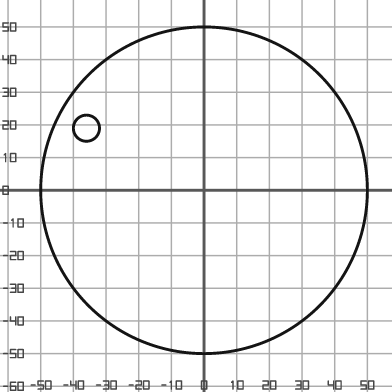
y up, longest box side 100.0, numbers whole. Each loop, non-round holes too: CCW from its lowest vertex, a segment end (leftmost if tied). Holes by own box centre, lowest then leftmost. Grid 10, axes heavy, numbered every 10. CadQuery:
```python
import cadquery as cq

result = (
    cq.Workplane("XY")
    .moveTo(0.0, 0.0)
    .circle(50.0)
    .moveTo(-36.0, 19.0)
    .circle(4.0)
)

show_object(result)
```